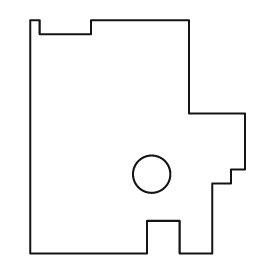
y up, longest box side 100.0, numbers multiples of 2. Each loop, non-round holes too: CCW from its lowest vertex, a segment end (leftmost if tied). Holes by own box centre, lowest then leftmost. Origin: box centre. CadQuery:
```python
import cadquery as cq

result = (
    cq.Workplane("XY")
    .moveTo(-46.0, -50.0)
    .lineTo(4.0, -50.0)
    .lineTo(4.0, -36.0)
    .lineTo(18.0, -36.0)
    .lineTo(18.0, -50.0)
    .lineTo(32.0, -50.0)
    .lineTo(32.0, -20.0)
    .lineTo(40.0, -20.0)
    .lineTo(40.0, -14.0)
    .lineTo(46.0, -14.0)
    .lineTo(46.0, 10.0)
    .lineTo(22.0, 10.0)
    .lineTo(22.0, 50.0)
    .lineTo(-20.0, 50.0)
    .lineTo(-20.0, 44.0)
    .lineTo(-42.0, 44.0)
    .lineTo(-42.0, 50.0)
    .lineTo(-46.0, 50.0)
    .close()
    .moveTo(6.0, -16.0)
    .circle(8.0)
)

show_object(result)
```